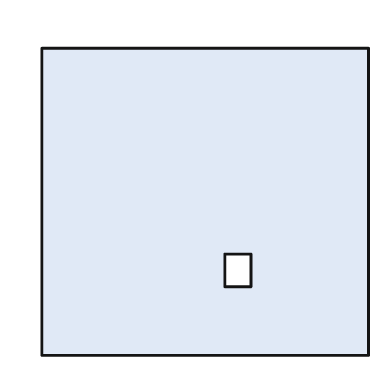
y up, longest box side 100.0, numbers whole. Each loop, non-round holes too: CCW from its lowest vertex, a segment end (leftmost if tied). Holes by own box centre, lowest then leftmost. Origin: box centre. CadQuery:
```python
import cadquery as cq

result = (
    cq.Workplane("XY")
    .moveTo(-50.0, -47.0)
    .lineTo(50.0, -47.0)
    .lineTo(50.0, 47.0)
    .lineTo(-50.0, 47.0)
    .close()
    .moveTo(6.0, -26.0)
    .lineTo(14.0, -26.0)
    .lineTo(14.0, -16.0)
    .lineTo(6.0, -16.0)
    .close()
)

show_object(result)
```